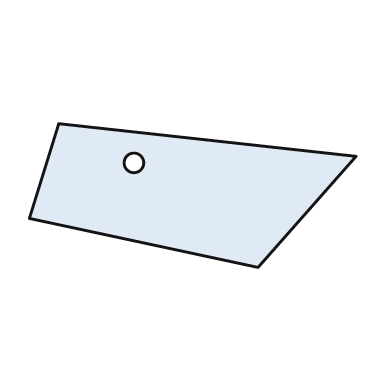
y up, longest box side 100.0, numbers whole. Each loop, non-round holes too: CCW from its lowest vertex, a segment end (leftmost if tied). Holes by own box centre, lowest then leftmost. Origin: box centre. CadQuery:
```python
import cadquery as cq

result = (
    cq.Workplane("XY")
    .moveTo(20.0, -22.0)
    .lineTo(50.0, 12.0)
    .lineTo(-41.0, 22.0)
    .lineTo(-50.0, -7.0)
    .close()
    .moveTo(-18.0, 10.0)
    .circle(3.0)
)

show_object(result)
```